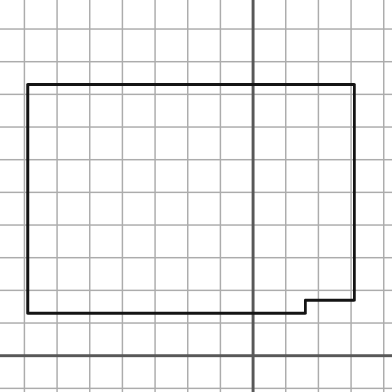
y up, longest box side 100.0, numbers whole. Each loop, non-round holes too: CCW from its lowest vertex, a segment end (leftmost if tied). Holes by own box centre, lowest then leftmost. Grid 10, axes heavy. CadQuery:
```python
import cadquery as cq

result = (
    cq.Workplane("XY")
    .moveTo(-69.0, 13.0)
    .lineTo(16.0, 13.0)
    .lineTo(16.0, 17.0)
    .lineTo(31.0, 17.0)
    .lineTo(31.0, 83.0)
    .lineTo(-69.0, 83.0)
    .close()
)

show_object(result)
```